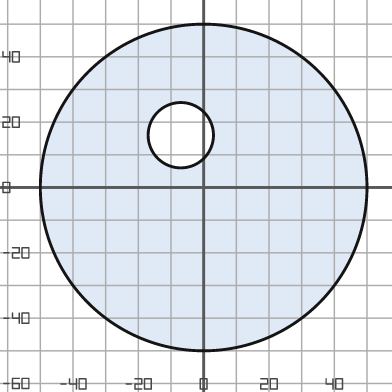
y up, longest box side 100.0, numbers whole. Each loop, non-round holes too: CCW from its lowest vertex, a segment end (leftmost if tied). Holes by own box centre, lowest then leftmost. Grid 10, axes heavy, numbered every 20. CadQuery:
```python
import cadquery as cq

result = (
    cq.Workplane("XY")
    .moveTo(0.0, 0.0)
    .circle(50.0)
    .moveTo(-7.0, 16.0)
    .circle(10.0)
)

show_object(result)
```